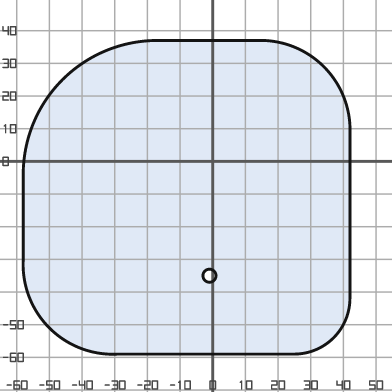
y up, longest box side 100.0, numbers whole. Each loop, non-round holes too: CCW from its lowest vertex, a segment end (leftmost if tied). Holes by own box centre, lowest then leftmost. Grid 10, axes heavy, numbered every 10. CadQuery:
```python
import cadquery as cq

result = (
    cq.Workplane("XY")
    .moveTo(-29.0, -59.0)
    .lineTo(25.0, -59.0)
    .threePointArc((37.0, -54.0), (42.0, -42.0))
    .lineTo(42.0, 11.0)
    .threePointArc((34.0, 29.0), (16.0, 37.0))
    .lineTo(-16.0, 37.0)
    .threePointArc((-46.0, 25.0), (-58.0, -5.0))
    .lineTo(-58.0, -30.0)
    .threePointArc((-50.0, -51.0), (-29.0, -59.0))
    .close()
    .moveTo(-1.0, -35.0)
    .circle(2.0)
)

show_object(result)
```